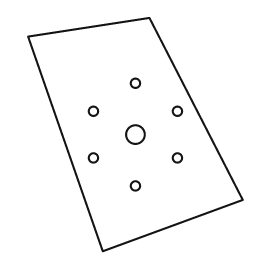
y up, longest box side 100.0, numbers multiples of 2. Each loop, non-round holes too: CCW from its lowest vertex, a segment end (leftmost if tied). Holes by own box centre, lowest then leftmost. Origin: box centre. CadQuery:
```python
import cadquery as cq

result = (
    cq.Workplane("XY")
    .moveTo(-14.0, -50.0)
    .lineTo(46.0, -28.0)
    .lineTo(6.0, 50.0)
    .lineTo(-46.0, 42.0)
    .close()
    .moveTo(0.0, -22.0)
    .circle(2.0)
    .moveTo(-18.0, -10.0)
    .circle(2.0)
    .moveTo(18.0, -10.0)
    .circle(2.0)
    .moveTo(0.0, 0.0)
    .circle(4.0)
    .moveTo(-18.0, 10.0)
    .circle(2.0)
    .moveTo(18.0, 10.0)
    .circle(2.0)
    .moveTo(0.0, 22.0)
    .circle(2.0)
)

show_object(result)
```